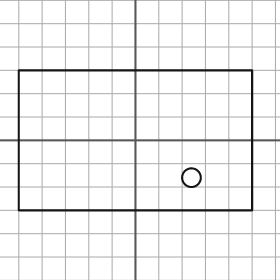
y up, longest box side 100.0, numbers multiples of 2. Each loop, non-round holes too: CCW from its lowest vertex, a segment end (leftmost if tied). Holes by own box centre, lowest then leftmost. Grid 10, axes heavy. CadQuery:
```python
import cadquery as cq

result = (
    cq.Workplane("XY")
    .moveTo(-50.0, -30.0)
    .lineTo(50.0, -30.0)
    .lineTo(50.0, 30.0)
    .lineTo(-50.0, 30.0)
    .close()
    .moveTo(24.0, -16.0)
    .circle(4.0)
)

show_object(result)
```